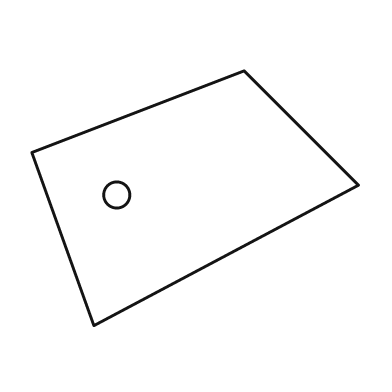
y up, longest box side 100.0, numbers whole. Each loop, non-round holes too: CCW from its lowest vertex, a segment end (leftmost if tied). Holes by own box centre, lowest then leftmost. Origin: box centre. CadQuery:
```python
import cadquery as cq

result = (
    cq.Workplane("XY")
    .moveTo(-31.0, -39.0)
    .lineTo(50.0, 4.0)
    .lineTo(15.0, 39.0)
    .lineTo(-50.0, 14.0)
    .close()
    .moveTo(-24.0, 1.0)
    .circle(4.0)
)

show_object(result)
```